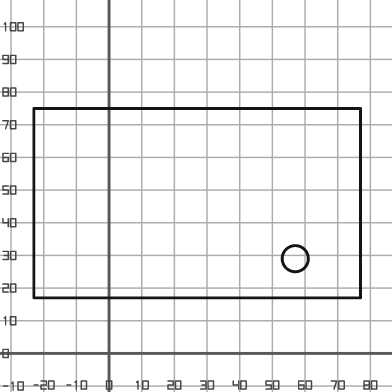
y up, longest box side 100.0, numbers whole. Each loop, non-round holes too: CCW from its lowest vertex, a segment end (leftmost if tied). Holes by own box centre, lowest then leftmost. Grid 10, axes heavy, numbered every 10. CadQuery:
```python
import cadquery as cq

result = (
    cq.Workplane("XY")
    .moveTo(-23.0, 17.0)
    .lineTo(77.0, 17.0)
    .lineTo(77.0, 75.0)
    .lineTo(-23.0, 75.0)
    .close()
    .moveTo(57.0, 29.0)
    .circle(4.0)
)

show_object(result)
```